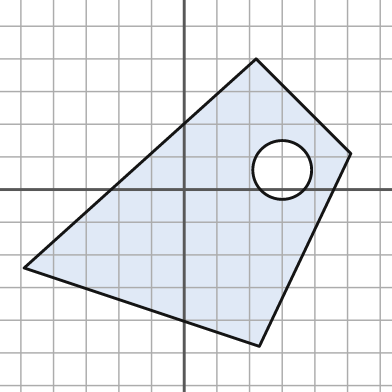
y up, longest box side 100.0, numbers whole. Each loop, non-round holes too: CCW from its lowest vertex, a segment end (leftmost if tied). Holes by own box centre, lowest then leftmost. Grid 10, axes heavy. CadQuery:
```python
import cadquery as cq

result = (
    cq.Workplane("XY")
    .moveTo(23.0, -48.0)
    .lineTo(51.0, 11.0)
    .lineTo(22.0, 40.0)
    .lineTo(-49.0, -24.0)
    .close()
    .moveTo(30.0, 6.0)
    .circle(9.0)
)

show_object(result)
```